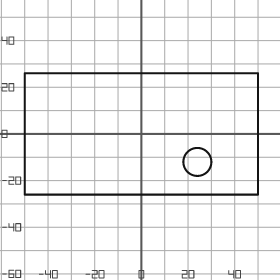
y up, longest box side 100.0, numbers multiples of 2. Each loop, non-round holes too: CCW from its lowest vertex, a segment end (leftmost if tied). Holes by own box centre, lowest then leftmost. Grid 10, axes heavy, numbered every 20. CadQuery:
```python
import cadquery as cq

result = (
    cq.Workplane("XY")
    .moveTo(-50.0, -26.0)
    .lineTo(50.0, -26.0)
    .lineTo(50.0, 26.0)
    .lineTo(-50.0, 26.0)
    .close()
    .moveTo(24.0, -12.0)
    .circle(6.0)
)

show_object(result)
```